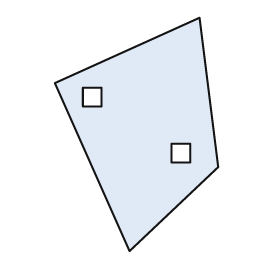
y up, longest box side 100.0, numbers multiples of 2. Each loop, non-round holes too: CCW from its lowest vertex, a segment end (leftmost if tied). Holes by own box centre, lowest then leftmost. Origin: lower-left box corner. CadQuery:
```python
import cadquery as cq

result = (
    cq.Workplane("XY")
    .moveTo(32.0, 0.0)
    .lineTo(70.0, 36.0)
    .lineTo(62.0, 100.0)
    .lineTo(0.0, 72.0)
    .close()
    .moveTo(50.0, 38.0)
    .lineTo(58.0, 38.0)
    .lineTo(58.0, 46.0)
    .lineTo(50.0, 46.0)
    .close()
    .moveTo(12.0, 62.0)
    .lineTo(20.0, 62.0)
    .lineTo(20.0, 70.0)
    .lineTo(12.0, 70.0)
    .close()
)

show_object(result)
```